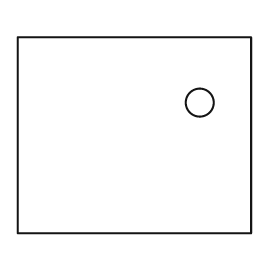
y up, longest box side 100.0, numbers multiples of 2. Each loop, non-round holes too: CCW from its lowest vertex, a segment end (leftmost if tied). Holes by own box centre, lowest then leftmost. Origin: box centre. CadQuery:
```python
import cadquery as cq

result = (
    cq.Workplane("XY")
    .moveTo(-50.0, -42.0)
    .lineTo(50.0, -42.0)
    .lineTo(50.0, 42.0)
    .lineTo(-50.0, 42.0)
    .close()
    .moveTo(28.0, 14.0)
    .circle(6.0)
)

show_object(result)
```